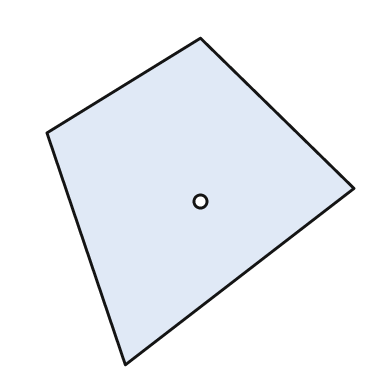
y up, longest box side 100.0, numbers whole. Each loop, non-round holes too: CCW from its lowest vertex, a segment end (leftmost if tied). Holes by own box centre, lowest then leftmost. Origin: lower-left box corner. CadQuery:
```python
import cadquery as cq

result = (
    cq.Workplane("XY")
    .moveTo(24.0, 0.0)
    .lineTo(94.0, 54.0)
    .lineTo(47.0, 100.0)
    .lineTo(0.0, 71.0)
    .close()
    .moveTo(47.0, 50.0)
    .circle(2.0)
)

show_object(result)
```